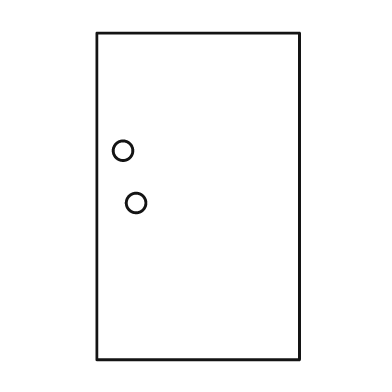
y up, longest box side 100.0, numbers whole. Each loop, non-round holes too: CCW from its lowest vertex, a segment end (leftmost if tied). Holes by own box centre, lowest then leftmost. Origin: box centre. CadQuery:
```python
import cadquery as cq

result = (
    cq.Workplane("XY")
    .moveTo(-31.0, -50.0)
    .lineTo(31.0, -50.0)
    .lineTo(31.0, 50.0)
    .lineTo(-31.0, 50.0)
    .close()
    .moveTo(-19.0, -2.0)
    .circle(3.0)
    .moveTo(-23.0, 14.0)
    .circle(3.0)
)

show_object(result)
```